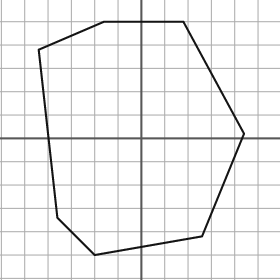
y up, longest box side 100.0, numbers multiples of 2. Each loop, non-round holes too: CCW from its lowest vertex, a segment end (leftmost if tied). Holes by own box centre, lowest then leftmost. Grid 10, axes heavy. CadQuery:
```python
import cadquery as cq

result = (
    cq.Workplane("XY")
    .moveTo(-20.0, -50.0)
    .lineTo(26.0, -42.0)
    .lineTo(44.0, 2.0)
    .lineTo(18.0, 50.0)
    .lineTo(-16.0, 50.0)
    .lineTo(-44.0, 38.0)
    .lineTo(-36.0, -34.0)
    .close()
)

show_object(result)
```